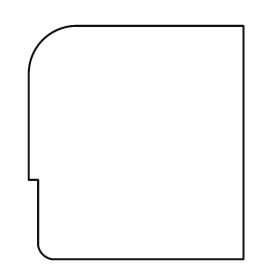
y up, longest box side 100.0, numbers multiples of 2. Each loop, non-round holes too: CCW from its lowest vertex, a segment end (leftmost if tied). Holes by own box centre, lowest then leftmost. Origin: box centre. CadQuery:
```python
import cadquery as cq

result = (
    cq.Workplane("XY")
    .moveTo(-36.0, -50.0)
    .lineTo(46.0, -50.0)
    .lineTo(46.0, 50.0)
    .lineTo(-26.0, 50.0)
    .threePointArc((-40.0, 44.0), (-46.0, 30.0))
    .lineTo(-46.0, -16.0)
    .lineTo(-42.0, -16.0)
    .lineTo(-42.0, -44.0)
    .threePointArc((-40.0, -48.0), (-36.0, -50.0))
    .close()
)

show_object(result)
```